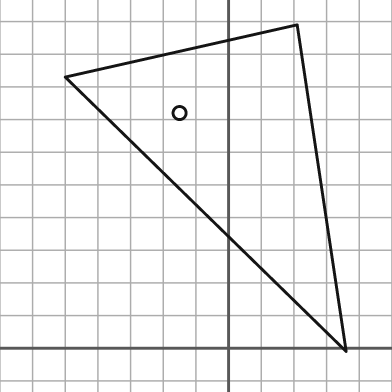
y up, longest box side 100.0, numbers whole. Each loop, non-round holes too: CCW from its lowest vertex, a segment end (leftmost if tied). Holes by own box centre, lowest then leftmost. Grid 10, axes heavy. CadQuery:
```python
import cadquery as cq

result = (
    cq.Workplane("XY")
    .moveTo(36.0, -1.0)
    .lineTo(21.0, 99.0)
    .lineTo(-50.0, 83.0)
    .close()
    .moveTo(-15.0, 72.0)
    .circle(2.0)
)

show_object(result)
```